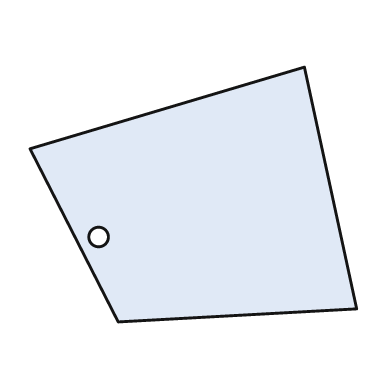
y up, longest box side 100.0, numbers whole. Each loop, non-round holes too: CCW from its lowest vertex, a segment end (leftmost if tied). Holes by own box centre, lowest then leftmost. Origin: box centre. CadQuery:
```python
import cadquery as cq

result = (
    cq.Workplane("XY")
    .moveTo(-23.0, -39.0)
    .lineTo(50.0, -35.0)
    .lineTo(34.0, 39.0)
    .lineTo(-50.0, 14.0)
    .close()
    .moveTo(-29.0, -13.0)
    .circle(3.0)
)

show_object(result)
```